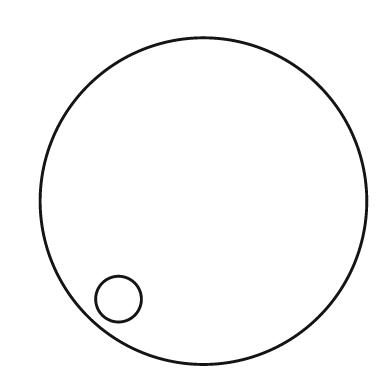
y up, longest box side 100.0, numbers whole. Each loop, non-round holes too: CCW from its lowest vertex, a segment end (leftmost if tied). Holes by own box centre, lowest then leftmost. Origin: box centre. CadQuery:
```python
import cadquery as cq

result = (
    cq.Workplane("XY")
    .moveTo(0.0, 0.0)
    .circle(50.0)
    .moveTo(-26.0, -30.0)
    .circle(7.0)
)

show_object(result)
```